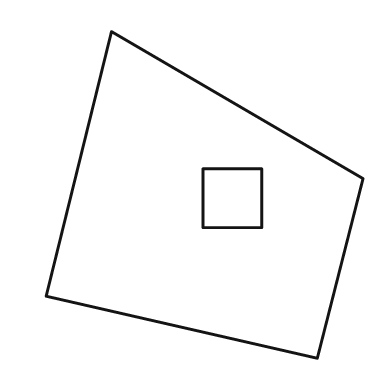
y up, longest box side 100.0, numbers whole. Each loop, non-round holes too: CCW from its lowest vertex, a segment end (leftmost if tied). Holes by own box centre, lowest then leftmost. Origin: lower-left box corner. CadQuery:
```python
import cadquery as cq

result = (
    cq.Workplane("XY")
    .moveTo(83.0, 0.0)
    .lineTo(97.0, 55.0)
    .lineTo(20.0, 100.0)
    .lineTo(0.0, 19.0)
    .close()
    .moveTo(48.0, 40.0)
    .lineTo(66.0, 40.0)
    .lineTo(66.0, 58.0)
    .lineTo(48.0, 58.0)
    .close()
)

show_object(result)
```